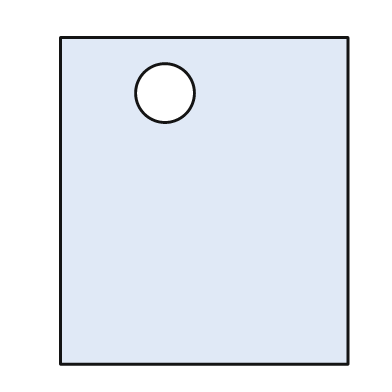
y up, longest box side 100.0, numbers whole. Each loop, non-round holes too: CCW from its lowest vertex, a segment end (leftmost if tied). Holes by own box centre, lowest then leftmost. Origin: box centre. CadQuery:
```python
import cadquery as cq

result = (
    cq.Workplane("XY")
    .moveTo(-44.0, -50.0)
    .lineTo(44.0, -50.0)
    .lineTo(44.0, 50.0)
    .lineTo(-44.0, 50.0)
    .close()
    .moveTo(-12.0, 33.0)
    .circle(9.0)
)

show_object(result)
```